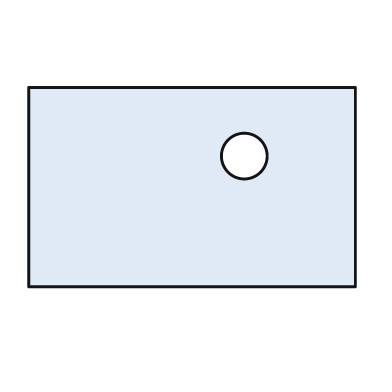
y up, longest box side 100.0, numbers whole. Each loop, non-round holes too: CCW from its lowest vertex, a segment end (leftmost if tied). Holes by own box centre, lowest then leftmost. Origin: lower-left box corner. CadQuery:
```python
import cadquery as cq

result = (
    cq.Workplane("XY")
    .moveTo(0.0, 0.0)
    .lineTo(100.0, 0.0)
    .lineTo(100.0, 61.0)
    .lineTo(0.0, 61.0)
    .close()
    .moveTo(66.0, 40.0)
    .circle(7.0)
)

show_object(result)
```